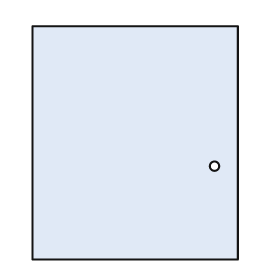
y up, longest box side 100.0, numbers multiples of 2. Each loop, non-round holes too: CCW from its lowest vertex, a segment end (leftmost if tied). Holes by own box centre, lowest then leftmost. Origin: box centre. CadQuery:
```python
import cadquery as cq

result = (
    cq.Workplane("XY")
    .moveTo(-44.0, -50.0)
    .lineTo(44.0, -50.0)
    .lineTo(44.0, 50.0)
    .lineTo(-44.0, 50.0)
    .close()
    .moveTo(34.0, -10.0)
    .circle(2.0)
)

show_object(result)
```